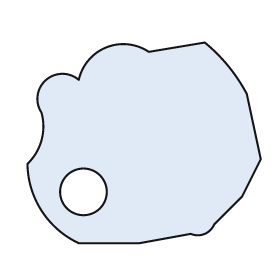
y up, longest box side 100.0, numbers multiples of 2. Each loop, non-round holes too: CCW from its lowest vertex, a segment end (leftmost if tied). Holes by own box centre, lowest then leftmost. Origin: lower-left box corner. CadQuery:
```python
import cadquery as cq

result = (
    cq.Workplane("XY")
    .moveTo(22.0, 0.0)
    .lineTo(48.0, 0.0)
    .lineTo(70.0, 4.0)
    .threePointArc((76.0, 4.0), (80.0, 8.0))
    .lineTo(92.0, 20.0)
    .lineTo(100.0, 36.0)
    .lineTo(94.0, 64.0)
    .threePointArc((86.0, 76.0), (76.0, 86.0))
    .lineTo(52.0, 82.0)
    .threePointArc((34.0, 84.0), (22.0, 70.0))
    .threePointArc((8.0, 70.0), (6.0, 56.0))
    .threePointArc((6.0, 44.0), (0.0, 34.0))
    .threePointArc((6.0, 14.0), (22.0, 0.0))
    .close()
    .moveTo(24.0, 22.0)
    .circle(10.0)
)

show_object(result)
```